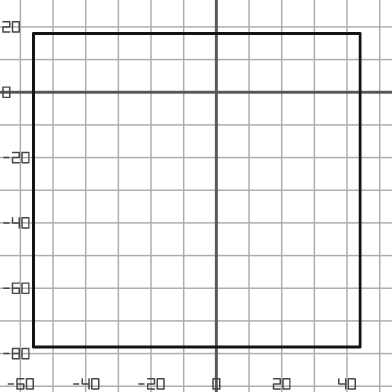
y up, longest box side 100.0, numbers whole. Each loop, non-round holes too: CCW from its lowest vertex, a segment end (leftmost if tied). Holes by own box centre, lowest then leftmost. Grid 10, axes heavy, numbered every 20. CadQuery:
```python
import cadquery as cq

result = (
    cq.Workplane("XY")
    .moveTo(-56.0, -78.0)
    .lineTo(44.0, -78.0)
    .lineTo(44.0, 18.0)
    .lineTo(-56.0, 18.0)
    .close()
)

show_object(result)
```